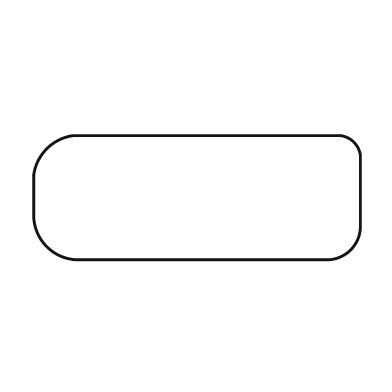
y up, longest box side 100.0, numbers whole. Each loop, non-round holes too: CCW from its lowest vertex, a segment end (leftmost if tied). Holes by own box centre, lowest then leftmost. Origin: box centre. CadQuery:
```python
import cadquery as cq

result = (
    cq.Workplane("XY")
    .moveTo(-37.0, -19.0)
    .lineTo(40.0, -19.0)
    .threePointArc((47.0, -16.0), (50.0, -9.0))
    .lineTo(50.0, 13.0)
    .threePointArc((48.0, 17.0), (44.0, 19.0))
    .lineTo(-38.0, 19.0)
    .threePointArc((-46.0, 15.0), (-50.0, 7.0))
    .lineTo(-50.0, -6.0)
    .threePointArc((-46.0, -15.0), (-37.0, -19.0))
    .close()
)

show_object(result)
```